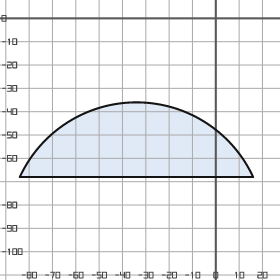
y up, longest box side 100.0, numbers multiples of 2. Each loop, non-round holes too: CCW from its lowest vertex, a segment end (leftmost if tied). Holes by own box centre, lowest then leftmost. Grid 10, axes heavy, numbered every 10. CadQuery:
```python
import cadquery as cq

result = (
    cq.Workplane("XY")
    .moveTo(-84.0, -68.0)
    .lineTo(16.0, -68.0)
    .threePointArc((-34.0, -36.0), (-84.0, -68.0))
    .close()
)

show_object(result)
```